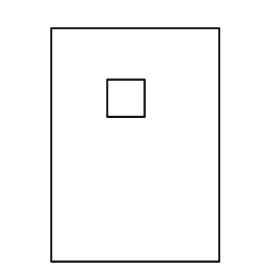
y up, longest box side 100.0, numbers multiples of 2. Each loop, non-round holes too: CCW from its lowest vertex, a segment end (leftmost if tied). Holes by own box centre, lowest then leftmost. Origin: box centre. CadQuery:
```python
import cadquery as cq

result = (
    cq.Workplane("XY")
    .moveTo(-36.0, -50.0)
    .lineTo(36.0, -50.0)
    .lineTo(36.0, 50.0)
    .lineTo(-36.0, 50.0)
    .close()
    .moveTo(-12.0, 12.0)
    .lineTo(4.0, 12.0)
    .lineTo(4.0, 28.0)
    .lineTo(-12.0, 28.0)
    .close()
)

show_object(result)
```